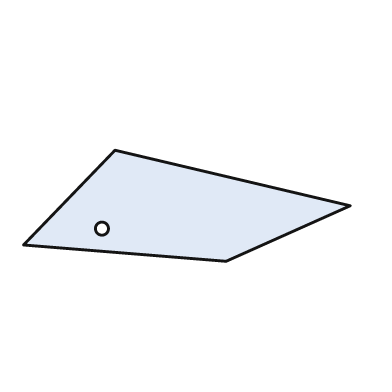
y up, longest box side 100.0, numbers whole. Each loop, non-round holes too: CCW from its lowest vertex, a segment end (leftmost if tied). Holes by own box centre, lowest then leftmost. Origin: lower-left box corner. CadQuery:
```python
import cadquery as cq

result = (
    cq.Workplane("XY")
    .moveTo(62.0, 0.0)
    .lineTo(100.0, 17.0)
    .lineTo(28.0, 34.0)
    .lineTo(0.0, 5.0)
    .close()
    .moveTo(24.0, 10.0)
    .circle(2.0)
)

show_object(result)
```